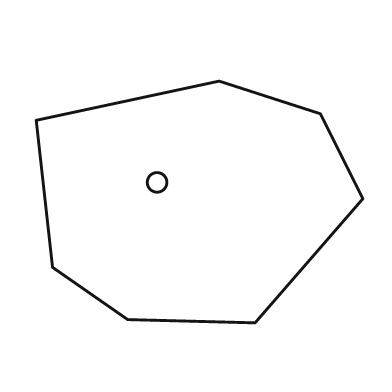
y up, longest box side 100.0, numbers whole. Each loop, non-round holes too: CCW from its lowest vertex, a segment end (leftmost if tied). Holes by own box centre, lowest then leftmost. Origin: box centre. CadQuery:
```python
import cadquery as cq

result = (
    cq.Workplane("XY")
    .moveTo(17.0, -37.0)
    .lineTo(50.0, 1.0)
    .lineTo(37.0, 27.0)
    .lineTo(6.0, 37.0)
    .lineTo(-50.0, 25.0)
    .lineTo(-45.0, -20.0)
    .lineTo(-22.0, -36.0)
    .close()
    .moveTo(-13.0, 6.0)
    .circle(3.0)
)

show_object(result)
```